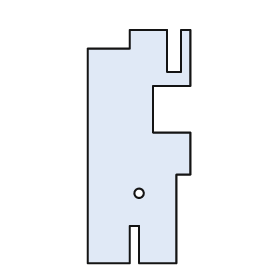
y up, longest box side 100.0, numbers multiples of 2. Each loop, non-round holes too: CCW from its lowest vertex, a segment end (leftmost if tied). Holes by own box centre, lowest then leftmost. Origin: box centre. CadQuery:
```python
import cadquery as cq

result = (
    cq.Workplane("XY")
    .moveTo(-22.0, -50.0)
    .lineTo(-4.0, -50.0)
    .lineTo(-4.0, -34.0)
    .lineTo(0.0, -34.0)
    .lineTo(0.0, -50.0)
    .lineTo(16.0, -50.0)
    .lineTo(16.0, -12.0)
    .lineTo(22.0, -12.0)
    .lineTo(22.0, 6.0)
    .lineTo(6.0, 6.0)
    .lineTo(6.0, 26.0)
    .lineTo(22.0, 26.0)
    .lineTo(22.0, 50.0)
    .lineTo(18.0, 50.0)
    .lineTo(18.0, 32.0)
    .lineTo(12.0, 32.0)
    .lineTo(12.0, 50.0)
    .lineTo(-4.0, 50.0)
    .lineTo(-4.0, 42.0)
    .lineTo(-22.0, 42.0)
    .close()
    .moveTo(0.0, -20.0)
    .circle(2.0)
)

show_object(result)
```